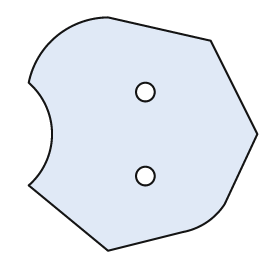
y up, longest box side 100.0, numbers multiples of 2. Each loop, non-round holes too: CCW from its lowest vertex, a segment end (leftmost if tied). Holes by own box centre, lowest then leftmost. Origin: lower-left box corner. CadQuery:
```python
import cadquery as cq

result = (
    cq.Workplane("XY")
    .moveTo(34.0, 0.0)
    .lineTo(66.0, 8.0)
    .threePointArc((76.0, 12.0), (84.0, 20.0))
    .lineTo(98.0, 50.0)
    .lineTo(78.0, 90.0)
    .lineTo(34.0, 100.0)
    .threePointArc((12.0, 92.0), (0.0, 72.0))
    .threePointArc((10.0, 50.0), (0.0, 28.0))
    .close()
    .moveTo(50.0, 32.0)
    .circle(4.0)
    .moveTo(50.0, 68.0)
    .circle(4.0)
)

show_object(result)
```